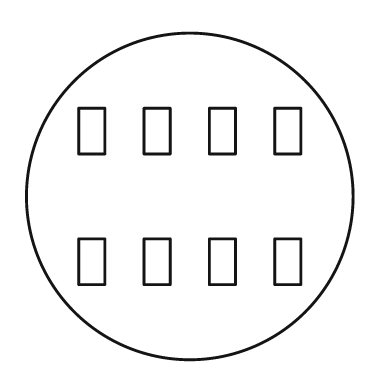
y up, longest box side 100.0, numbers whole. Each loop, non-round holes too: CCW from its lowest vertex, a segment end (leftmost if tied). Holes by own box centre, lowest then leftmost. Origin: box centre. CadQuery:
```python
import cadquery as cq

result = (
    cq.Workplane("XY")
    .moveTo(0.0, 0.0)
    .circle(50.0)
    .moveTo(-34.0, -27.0)
    .lineTo(-26.0, -27.0)
    .lineTo(-26.0, -13.0)
    .lineTo(-34.0, -13.0)
    .close()
    .moveTo(-14.0, -27.0)
    .lineTo(-6.0, -27.0)
    .lineTo(-6.0, -13.0)
    .lineTo(-14.0, -13.0)
    .close()
    .moveTo(6.0, -27.0)
    .lineTo(14.0, -27.0)
    .lineTo(14.0, -13.0)
    .lineTo(6.0, -13.0)
    .close()
    .moveTo(26.0, -27.0)
    .lineTo(34.0, -27.0)
    .lineTo(34.0, -13.0)
    .lineTo(26.0, -13.0)
    .close()
    .moveTo(-34.0, 13.0)
    .lineTo(-26.0, 13.0)
    .lineTo(-26.0, 27.0)
    .lineTo(-34.0, 27.0)
    .close()
    .moveTo(-14.0, 13.0)
    .lineTo(-6.0, 13.0)
    .lineTo(-6.0, 27.0)
    .lineTo(-14.0, 27.0)
    .close()
    .moveTo(6.0, 13.0)
    .lineTo(14.0, 13.0)
    .lineTo(14.0, 27.0)
    .lineTo(6.0, 27.0)
    .close()
    .moveTo(26.0, 13.0)
    .lineTo(34.0, 13.0)
    .lineTo(34.0, 27.0)
    .lineTo(26.0, 27.0)
    .close()
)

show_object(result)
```